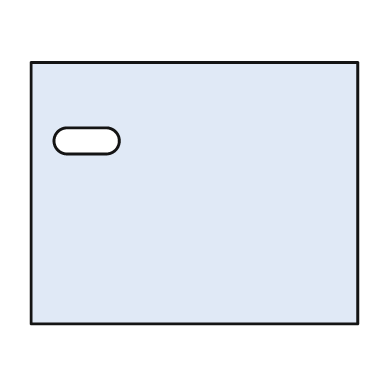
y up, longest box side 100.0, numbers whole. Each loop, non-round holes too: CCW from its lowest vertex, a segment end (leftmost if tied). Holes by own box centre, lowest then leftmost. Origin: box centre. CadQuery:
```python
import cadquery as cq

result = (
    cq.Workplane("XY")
    .moveTo(-50.0, -40.0)
    .lineTo(50.0, -40.0)
    .lineTo(50.0, 40.0)
    .lineTo(-50.0, 40.0)
    .close()
    .moveTo(-39.0, 12.0)
    .lineTo(-27.0, 12.0)
    .threePointArc((-23.0, 16.0), (-27.0, 20.0))
    .lineTo(-39.0, 20.0)
    .threePointArc((-43.0, 16.0), (-39.0, 12.0))
    .close()
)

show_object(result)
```